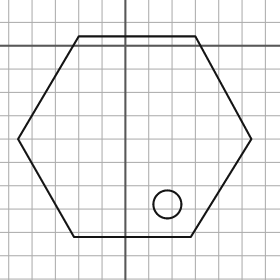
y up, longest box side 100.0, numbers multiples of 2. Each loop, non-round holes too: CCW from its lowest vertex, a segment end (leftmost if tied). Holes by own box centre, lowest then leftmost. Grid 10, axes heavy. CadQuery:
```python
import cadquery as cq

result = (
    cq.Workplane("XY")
    .moveTo(-22.0, -82.0)
    .lineTo(28.0, -82.0)
    .lineTo(54.0, -40.0)
    .lineTo(30.0, 4.0)
    .lineTo(-20.0, 4.0)
    .lineTo(-46.0, -40.0)
    .close()
    .moveTo(18.0, -68.0)
    .circle(6.0)
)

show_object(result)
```